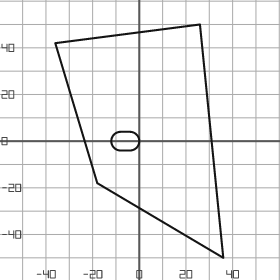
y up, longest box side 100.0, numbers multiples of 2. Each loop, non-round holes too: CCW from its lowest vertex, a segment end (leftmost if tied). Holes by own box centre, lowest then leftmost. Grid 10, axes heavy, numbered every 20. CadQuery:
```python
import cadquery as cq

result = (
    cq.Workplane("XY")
    .moveTo(36.0, -50.0)
    .lineTo(26.0, 50.0)
    .lineTo(-36.0, 42.0)
    .lineTo(-18.0, -18.0)
    .close()
    .moveTo(-8.0, -4.0)
    .lineTo(-4.0, -4.0)
    .threePointArc((0.0, 0.0), (-4.0, 4.0))
    .lineTo(-8.0, 4.0)
    .threePointArc((-12.0, 0.0), (-8.0, -4.0))
    .close()
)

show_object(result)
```